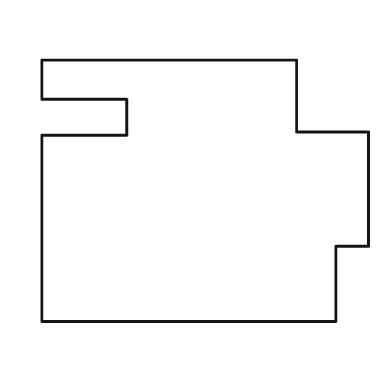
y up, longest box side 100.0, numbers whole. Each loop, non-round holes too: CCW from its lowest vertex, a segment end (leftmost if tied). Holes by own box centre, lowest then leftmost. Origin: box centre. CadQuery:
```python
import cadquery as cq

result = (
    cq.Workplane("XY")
    .moveTo(-50.0, -40.0)
    .lineTo(40.0, -40.0)
    .lineTo(40.0, -17.0)
    .lineTo(50.0, -17.0)
    .lineTo(50.0, 18.0)
    .lineTo(28.0, 18.0)
    .lineTo(28.0, 40.0)
    .lineTo(-50.0, 40.0)
    .lineTo(-50.0, 28.0)
    .lineTo(-24.0, 28.0)
    .lineTo(-24.0, 17.0)
    .lineTo(-50.0, 17.0)
    .close()
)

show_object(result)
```